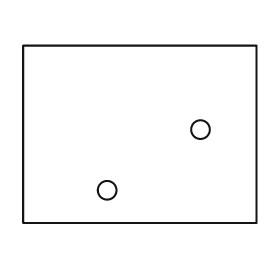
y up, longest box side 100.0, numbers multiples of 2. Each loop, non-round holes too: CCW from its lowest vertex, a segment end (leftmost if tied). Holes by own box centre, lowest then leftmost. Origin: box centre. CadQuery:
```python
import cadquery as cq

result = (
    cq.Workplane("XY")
    .moveTo(-50.0, -38.0)
    .lineTo(50.0, -38.0)
    .lineTo(50.0, 38.0)
    .lineTo(-50.0, 38.0)
    .close()
    .moveTo(-14.0, -24.0)
    .circle(4.0)
    .moveTo(26.0, 2.0)
    .circle(4.0)
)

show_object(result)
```